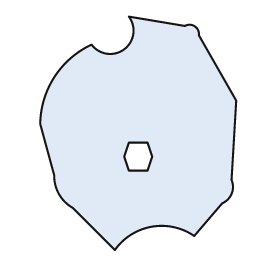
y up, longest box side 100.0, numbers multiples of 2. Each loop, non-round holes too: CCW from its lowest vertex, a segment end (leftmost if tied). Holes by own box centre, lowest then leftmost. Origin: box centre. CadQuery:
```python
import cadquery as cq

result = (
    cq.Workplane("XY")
    .moveTo(-10.0, -50.0)
    .threePointArc((6.0, -40.0), (24.0, -44.0))
    .lineTo(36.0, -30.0)
    .threePointArc((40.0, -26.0), (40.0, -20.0))
    .lineTo(42.0, 14.0)
    .lineTo(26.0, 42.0)
    .threePointArc((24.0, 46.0), (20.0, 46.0))
    .lineTo(-4.0, 50.0)
    .threePointArc((-6.0, 36.0), (-20.0, 38.0))
    .threePointArc((-36.0, 24.0), (-42.0, 4.0))
    .lineTo(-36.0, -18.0)
    .threePointArc((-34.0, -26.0), (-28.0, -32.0))
    .close()
    .moveTo(-4.0, -16.0)
    .lineTo(4.0, -16.0)
    .lineTo(6.0, -10.0)
    .lineTo(4.0, -4.0)
    .lineTo(-4.0, -4.0)
    .lineTo(-6.0, -10.0)
    .close()
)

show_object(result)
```